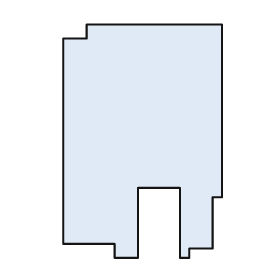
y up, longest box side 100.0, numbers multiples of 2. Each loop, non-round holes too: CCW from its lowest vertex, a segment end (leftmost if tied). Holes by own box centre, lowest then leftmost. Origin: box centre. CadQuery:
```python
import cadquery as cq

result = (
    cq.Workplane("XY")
    .moveTo(-12.0, -50.0)
    .lineTo(-2.0, -50.0)
    .lineTo(-2.0, -20.0)
    .lineTo(16.0, -20.0)
    .lineTo(16.0, -50.0)
    .lineTo(20.0, -50.0)
    .lineTo(20.0, -46.0)
    .lineTo(30.0, -46.0)
    .lineTo(30.0, -24.0)
    .lineTo(34.0, -24.0)
    .lineTo(34.0, 50.0)
    .lineTo(-24.0, 50.0)
    .lineTo(-24.0, 44.0)
    .lineTo(-34.0, 44.0)
    .lineTo(-34.0, -44.0)
    .lineTo(-12.0, -44.0)
    .close()
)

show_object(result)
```